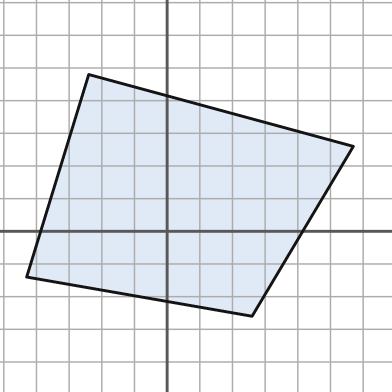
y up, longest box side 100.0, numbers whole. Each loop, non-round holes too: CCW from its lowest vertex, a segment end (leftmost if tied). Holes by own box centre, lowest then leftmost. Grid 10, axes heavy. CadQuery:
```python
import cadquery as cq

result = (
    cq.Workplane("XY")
    .moveTo(26.0, -26.0)
    .lineTo(57.0, 26.0)
    .lineTo(-24.0, 48.0)
    .lineTo(-43.0, -14.0)
    .close()
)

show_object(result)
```